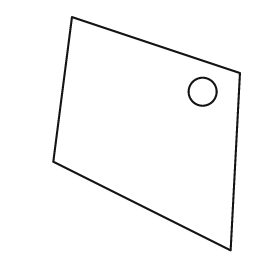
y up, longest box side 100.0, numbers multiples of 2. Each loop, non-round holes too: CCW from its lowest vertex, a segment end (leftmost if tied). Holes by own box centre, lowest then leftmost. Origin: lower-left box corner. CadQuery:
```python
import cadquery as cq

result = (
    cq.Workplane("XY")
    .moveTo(76.0, 0.0)
    .lineTo(80.0, 76.0)
    .lineTo(8.0, 100.0)
    .lineTo(0.0, 38.0)
    .close()
    .moveTo(64.0, 68.0)
    .circle(6.0)
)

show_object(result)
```